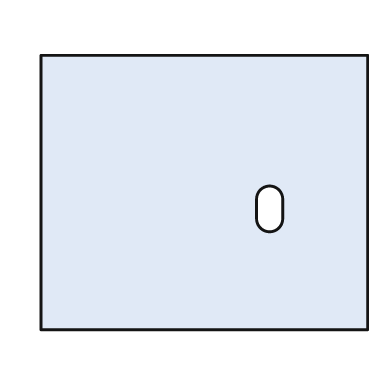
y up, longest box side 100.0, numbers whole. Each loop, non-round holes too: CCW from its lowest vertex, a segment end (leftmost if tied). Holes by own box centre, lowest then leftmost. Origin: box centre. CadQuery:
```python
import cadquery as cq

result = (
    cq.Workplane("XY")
    .moveTo(-50.0, -42.0)
    .lineTo(50.0, -42.0)
    .lineTo(50.0, 42.0)
    .lineTo(-50.0, 42.0)
    .close()
    .moveTo(16.0, -8.0)
    .threePointArc((20.0, -12.0), (24.0, -8.0))
    .lineTo(24.0, -2.0)
    .threePointArc((20.0, 2.0), (16.0, -2.0))
    .close()
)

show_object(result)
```